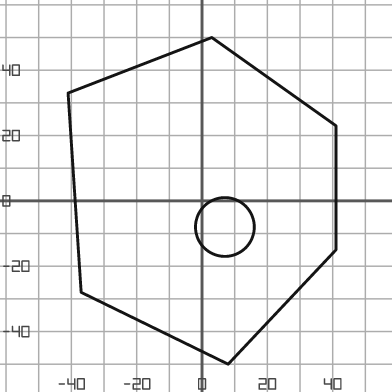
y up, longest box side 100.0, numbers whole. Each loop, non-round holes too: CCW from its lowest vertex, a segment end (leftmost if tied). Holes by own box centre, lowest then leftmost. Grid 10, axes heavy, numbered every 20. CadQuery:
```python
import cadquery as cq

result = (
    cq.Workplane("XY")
    .moveTo(8.0, -50.0)
    .lineTo(41.0, -15.0)
    .lineTo(41.0, 23.0)
    .lineTo(3.0, 50.0)
    .lineTo(-41.0, 33.0)
    .lineTo(-37.0, -28.0)
    .close()
    .moveTo(7.0, -8.0)
    .circle(9.0)
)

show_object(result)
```